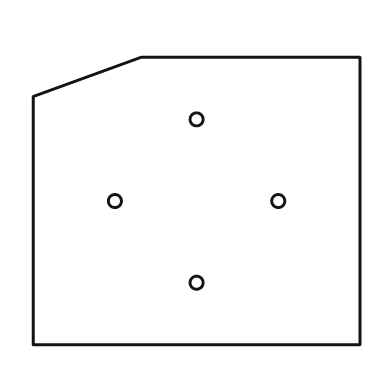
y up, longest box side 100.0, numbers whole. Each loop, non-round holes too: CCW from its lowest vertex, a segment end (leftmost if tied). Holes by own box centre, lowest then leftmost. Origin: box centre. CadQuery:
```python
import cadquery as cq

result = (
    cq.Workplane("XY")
    .moveTo(-50.0, -44.0)
    .lineTo(50.0, -44.0)
    .lineTo(50.0, 44.0)
    .lineTo(-17.0, 44.0)
    .lineTo(-50.0, 32.0)
    .close()
    .moveTo(0.0, -25.0)
    .circle(2.0)
    .moveTo(-25.0, 0.0)
    .circle(2.0)
    .moveTo(25.0, 0.0)
    .circle(2.0)
    .moveTo(0.0, 25.0)
    .circle(2.0)
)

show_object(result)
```